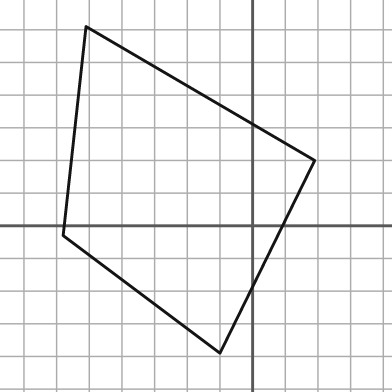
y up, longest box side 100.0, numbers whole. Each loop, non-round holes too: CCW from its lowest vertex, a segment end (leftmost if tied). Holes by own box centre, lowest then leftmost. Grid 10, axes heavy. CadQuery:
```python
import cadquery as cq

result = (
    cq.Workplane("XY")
    .moveTo(-10.0, -39.0)
    .lineTo(19.0, 20.0)
    .lineTo(-51.0, 61.0)
    .lineTo(-58.0, -3.0)
    .close()
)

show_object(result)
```